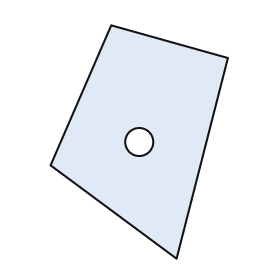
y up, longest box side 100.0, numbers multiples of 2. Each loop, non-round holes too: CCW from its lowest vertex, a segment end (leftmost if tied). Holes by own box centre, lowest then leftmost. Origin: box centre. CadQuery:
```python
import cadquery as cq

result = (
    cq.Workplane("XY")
    .moveTo(16.0, -50.0)
    .lineTo(38.0, 36.0)
    .lineTo(-12.0, 50.0)
    .lineTo(-38.0, -10.0)
    .close()
    .moveTo(0.0, 0.0)
    .circle(6.0)
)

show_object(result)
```